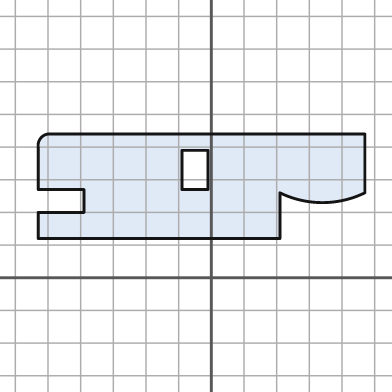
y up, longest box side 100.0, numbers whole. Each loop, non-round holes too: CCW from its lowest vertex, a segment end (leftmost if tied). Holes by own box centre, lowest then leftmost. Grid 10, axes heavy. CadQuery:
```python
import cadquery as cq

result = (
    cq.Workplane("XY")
    .moveTo(-53.0, 12.0)
    .lineTo(21.0, 12.0)
    .lineTo(21.0, 26.0)
    .threePointArc((34.0, 23.0), (47.0, 26.0))
    .lineTo(47.0, 44.0)
    .lineTo(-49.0, 44.0)
    .threePointArc((-52.0, 43.0), (-53.0, 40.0))
    .lineTo(-53.0, 27.0)
    .lineTo(-39.0, 27.0)
    .lineTo(-39.0, 20.0)
    .lineTo(-53.0, 20.0)
    .close()
    .moveTo(-9.0, 27.0)
    .lineTo(-1.0, 27.0)
    .lineTo(-1.0, 39.0)
    .lineTo(-9.0, 39.0)
    .close()
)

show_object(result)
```